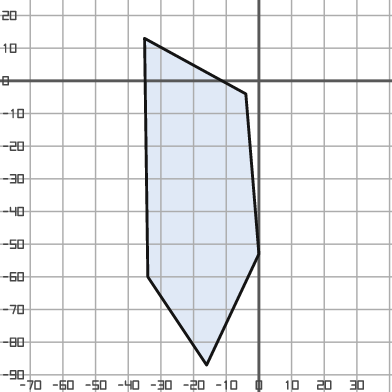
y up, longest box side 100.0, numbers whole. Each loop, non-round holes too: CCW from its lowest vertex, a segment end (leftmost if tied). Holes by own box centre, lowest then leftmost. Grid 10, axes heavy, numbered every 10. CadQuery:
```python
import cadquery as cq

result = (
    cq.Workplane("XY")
    .moveTo(-16.0, -87.0)
    .lineTo(0.0, -53.0)
    .lineTo(-4.0, -4.0)
    .lineTo(-35.0, 13.0)
    .lineTo(-34.0, -60.0)
    .close()
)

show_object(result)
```